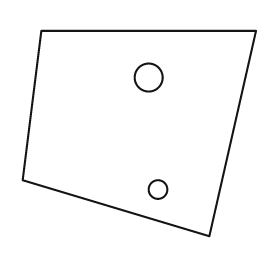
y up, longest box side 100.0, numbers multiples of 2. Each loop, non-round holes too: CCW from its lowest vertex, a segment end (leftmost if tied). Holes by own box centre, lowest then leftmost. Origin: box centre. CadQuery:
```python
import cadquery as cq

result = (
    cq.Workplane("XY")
    .moveTo(30.0, -44.0)
    .lineTo(50.0, 44.0)
    .lineTo(-42.0, 44.0)
    .lineTo(-50.0, -20.0)
    .close()
    .moveTo(8.0, -24.0)
    .circle(4.0)
    .moveTo(4.0, 24.0)
    .circle(6.0)
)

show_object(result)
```